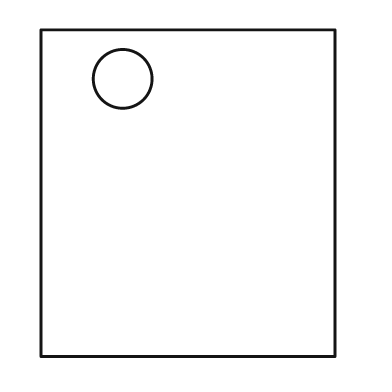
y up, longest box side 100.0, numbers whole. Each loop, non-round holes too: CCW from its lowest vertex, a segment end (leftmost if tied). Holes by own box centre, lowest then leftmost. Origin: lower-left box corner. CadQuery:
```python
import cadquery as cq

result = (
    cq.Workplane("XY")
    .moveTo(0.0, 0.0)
    .lineTo(90.0, 0.0)
    .lineTo(90.0, 100.0)
    .lineTo(0.0, 100.0)
    .close()
    .moveTo(25.0, 85.0)
    .circle(9.0)
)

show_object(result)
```